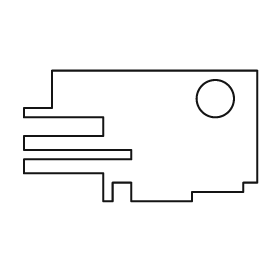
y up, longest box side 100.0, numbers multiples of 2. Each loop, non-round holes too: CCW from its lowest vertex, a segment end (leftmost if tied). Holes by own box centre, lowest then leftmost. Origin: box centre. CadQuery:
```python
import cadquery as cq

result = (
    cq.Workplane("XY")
    .moveTo(-16.0, -28.0)
    .lineTo(-12.0, -28.0)
    .lineTo(-12.0, -20.0)
    .lineTo(-4.0, -20.0)
    .lineTo(-4.0, -28.0)
    .lineTo(22.0, -28.0)
    .lineTo(22.0, -24.0)
    .lineTo(44.0, -24.0)
    .lineTo(44.0, -20.0)
    .lineTo(50.0, -20.0)
    .lineTo(50.0, 28.0)
    .lineTo(-38.0, 28.0)
    .lineTo(-38.0, 12.0)
    .lineTo(-50.0, 12.0)
    .lineTo(-50.0, 8.0)
    .lineTo(-16.0, 8.0)
    .lineTo(-16.0, 0.0)
    .lineTo(-50.0, 0.0)
    .lineTo(-50.0, -6.0)
    .lineTo(-4.0, -6.0)
    .lineTo(-4.0, -10.0)
    .lineTo(-50.0, -10.0)
    .lineTo(-50.0, -16.0)
    .lineTo(-16.0, -16.0)
    .close()
    .moveTo(32.0, 16.0)
    .circle(8.0)
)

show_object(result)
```